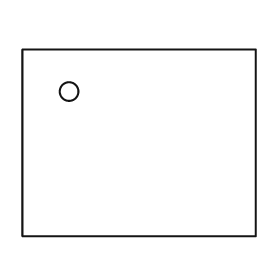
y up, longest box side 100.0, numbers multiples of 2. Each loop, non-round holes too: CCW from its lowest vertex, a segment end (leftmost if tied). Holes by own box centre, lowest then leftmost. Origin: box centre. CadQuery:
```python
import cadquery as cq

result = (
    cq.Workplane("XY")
    .moveTo(-50.0, -40.0)
    .lineTo(50.0, -40.0)
    .lineTo(50.0, 40.0)
    .lineTo(-50.0, 40.0)
    .close()
    .moveTo(-30.0, 22.0)
    .circle(4.0)
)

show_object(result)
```